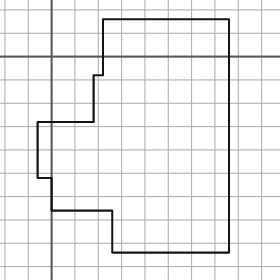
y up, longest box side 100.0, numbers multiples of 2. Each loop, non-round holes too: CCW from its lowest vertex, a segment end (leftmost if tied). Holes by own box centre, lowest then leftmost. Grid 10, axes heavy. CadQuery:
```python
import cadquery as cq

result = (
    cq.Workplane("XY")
    .moveTo(26.0, -84.0)
    .lineTo(76.0, -84.0)
    .lineTo(76.0, 16.0)
    .lineTo(22.0, 16.0)
    .lineTo(22.0, -8.0)
    .lineTo(18.0, -8.0)
    .lineTo(18.0, -28.0)
    .lineTo(-6.0, -28.0)
    .lineTo(-6.0, -52.0)
    .lineTo(0.0, -52.0)
    .lineTo(0.0, -66.0)
    .lineTo(26.0, -66.0)
    .close()
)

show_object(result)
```